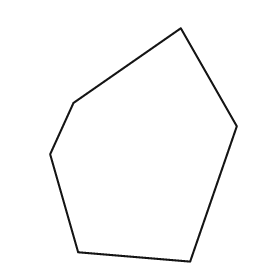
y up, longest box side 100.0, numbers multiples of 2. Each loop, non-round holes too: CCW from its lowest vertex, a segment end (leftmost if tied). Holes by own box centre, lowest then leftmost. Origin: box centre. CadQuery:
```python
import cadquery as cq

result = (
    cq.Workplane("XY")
    .moveTo(20.0, -50.0)
    .lineTo(40.0, 8.0)
    .lineTo(16.0, 50.0)
    .lineTo(-30.0, 18.0)
    .lineTo(-40.0, -4.0)
    .lineTo(-28.0, -46.0)
    .close()
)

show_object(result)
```